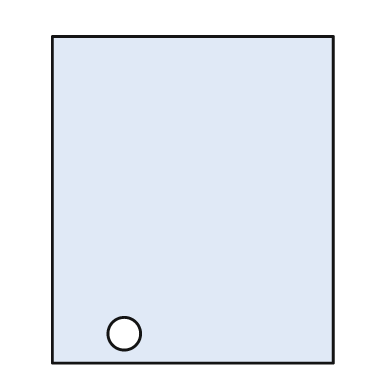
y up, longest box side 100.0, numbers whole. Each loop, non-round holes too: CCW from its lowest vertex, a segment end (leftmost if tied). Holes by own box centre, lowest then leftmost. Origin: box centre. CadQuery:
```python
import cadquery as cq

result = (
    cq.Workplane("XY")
    .moveTo(-43.0, -50.0)
    .lineTo(43.0, -50.0)
    .lineTo(43.0, 50.0)
    .lineTo(-43.0, 50.0)
    .close()
    .moveTo(-21.0, -41.0)
    .circle(5.0)
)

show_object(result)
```